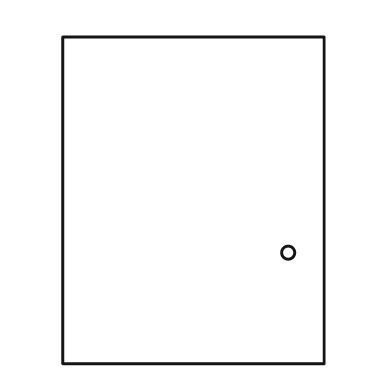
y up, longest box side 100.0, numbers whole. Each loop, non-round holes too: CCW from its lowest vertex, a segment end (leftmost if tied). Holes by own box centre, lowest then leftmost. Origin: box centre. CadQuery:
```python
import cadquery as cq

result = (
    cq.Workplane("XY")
    .moveTo(-40.0, -50.0)
    .lineTo(40.0, -50.0)
    .lineTo(40.0, 50.0)
    .lineTo(-40.0, 50.0)
    .close()
    .moveTo(29.0, -16.0)
    .circle(2.0)
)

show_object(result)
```